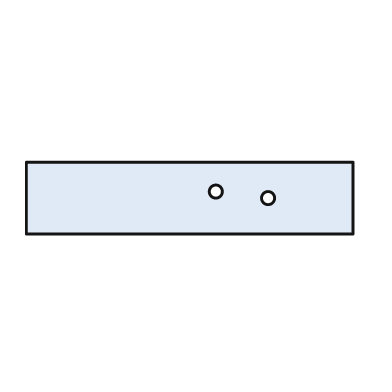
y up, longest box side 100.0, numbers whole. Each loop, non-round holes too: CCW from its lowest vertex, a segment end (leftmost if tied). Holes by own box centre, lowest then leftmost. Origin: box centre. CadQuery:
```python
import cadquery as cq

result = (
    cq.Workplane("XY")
    .moveTo(-50.0, -11.0)
    .lineTo(50.0, -11.0)
    .lineTo(50.0, 11.0)
    .lineTo(-50.0, 11.0)
    .close()
    .moveTo(24.0, 0.0)
    .circle(2.0)
    .moveTo(8.0, 2.0)
    .circle(2.0)
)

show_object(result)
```